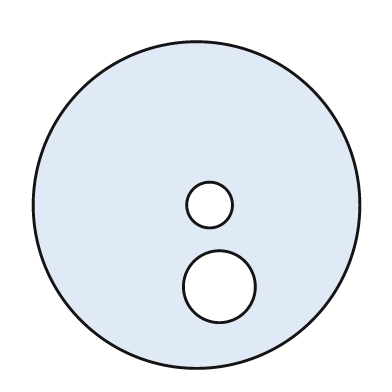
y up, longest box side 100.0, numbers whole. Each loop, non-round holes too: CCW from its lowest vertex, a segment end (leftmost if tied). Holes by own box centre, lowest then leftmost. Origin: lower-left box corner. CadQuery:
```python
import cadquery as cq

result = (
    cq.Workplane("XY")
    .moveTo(50.0, 50.0)
    .circle(50.0)
    .moveTo(57.0, 25.0)
    .circle(11.0)
    .moveTo(54.0, 50.0)
    .circle(7.0)
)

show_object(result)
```